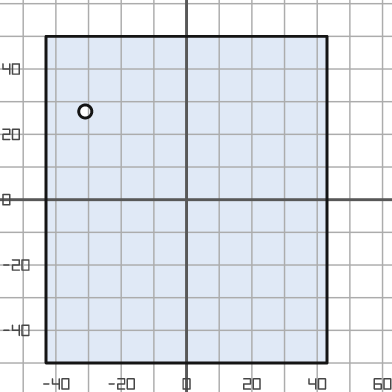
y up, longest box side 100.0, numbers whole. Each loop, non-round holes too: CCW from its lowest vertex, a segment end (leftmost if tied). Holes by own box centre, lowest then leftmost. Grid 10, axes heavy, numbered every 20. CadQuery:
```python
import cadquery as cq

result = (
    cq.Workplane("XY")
    .moveTo(-43.0, -50.0)
    .lineTo(43.0, -50.0)
    .lineTo(43.0, 50.0)
    .lineTo(-43.0, 50.0)
    .close()
    .moveTo(-31.0, 27.0)
    .circle(2.0)
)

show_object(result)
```